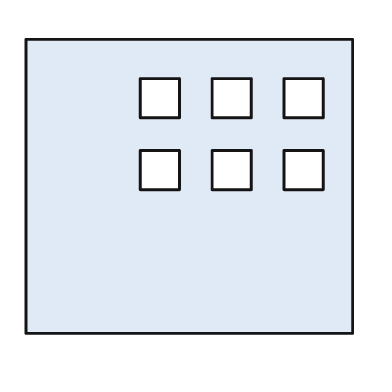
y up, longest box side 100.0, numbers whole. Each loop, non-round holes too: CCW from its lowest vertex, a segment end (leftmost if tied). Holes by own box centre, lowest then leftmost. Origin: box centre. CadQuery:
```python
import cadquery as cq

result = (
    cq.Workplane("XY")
    .moveTo(-50.0, -45.0)
    .lineTo(50.0, -45.0)
    .lineTo(50.0, 45.0)
    .lineTo(-50.0, 45.0)
    .close()
    .moveTo(-15.0, -1.0)
    .lineTo(-3.0, -1.0)
    .lineTo(-3.0, 11.0)
    .lineTo(-15.0, 11.0)
    .close()
    .moveTo(7.0, -1.0)
    .lineTo(19.0, -1.0)
    .lineTo(19.0, 11.0)
    .lineTo(7.0, 11.0)
    .close()
    .moveTo(29.0, -1.0)
    .lineTo(41.0, -1.0)
    .lineTo(41.0, 11.0)
    .lineTo(29.0, 11.0)
    .close()
    .moveTo(-15.0, 21.0)
    .lineTo(-3.0, 21.0)
    .lineTo(-3.0, 33.0)
    .lineTo(-15.0, 33.0)
    .close()
    .moveTo(7.0, 21.0)
    .lineTo(19.0, 21.0)
    .lineTo(19.0, 33.0)
    .lineTo(7.0, 33.0)
    .close()
    .moveTo(29.0, 21.0)
    .lineTo(41.0, 21.0)
    .lineTo(41.0, 33.0)
    .lineTo(29.0, 33.0)
    .close()
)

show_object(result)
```